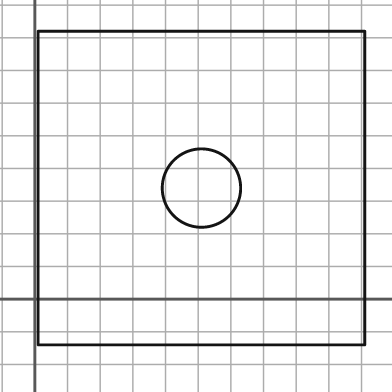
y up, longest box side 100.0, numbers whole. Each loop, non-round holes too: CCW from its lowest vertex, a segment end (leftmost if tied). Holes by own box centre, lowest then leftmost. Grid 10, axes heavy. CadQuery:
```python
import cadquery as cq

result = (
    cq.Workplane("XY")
    .moveTo(1.0, -14.0)
    .lineTo(101.0, -14.0)
    .lineTo(101.0, 82.0)
    .lineTo(1.0, 82.0)
    .close()
    .moveTo(51.0, 34.0)
    .circle(12.0)
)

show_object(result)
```